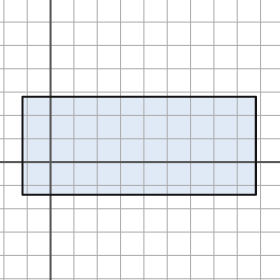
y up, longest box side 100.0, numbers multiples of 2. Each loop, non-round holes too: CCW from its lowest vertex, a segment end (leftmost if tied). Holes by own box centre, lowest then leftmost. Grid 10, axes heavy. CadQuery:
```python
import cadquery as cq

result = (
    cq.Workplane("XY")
    .moveTo(-12.0, -14.0)
    .lineTo(88.0, -14.0)
    .lineTo(88.0, 28.0)
    .lineTo(-12.0, 28.0)
    .close()
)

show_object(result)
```